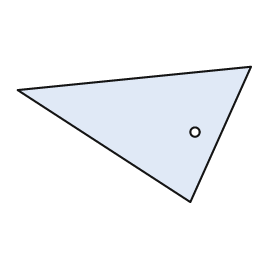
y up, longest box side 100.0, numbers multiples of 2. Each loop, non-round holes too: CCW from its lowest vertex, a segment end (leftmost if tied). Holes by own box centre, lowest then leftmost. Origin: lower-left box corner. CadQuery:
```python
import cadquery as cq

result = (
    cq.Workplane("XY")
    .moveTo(74.0, 0.0)
    .lineTo(100.0, 58.0)
    .lineTo(0.0, 48.0)
    .close()
    .moveTo(76.0, 30.0)
    .circle(2.0)
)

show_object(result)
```